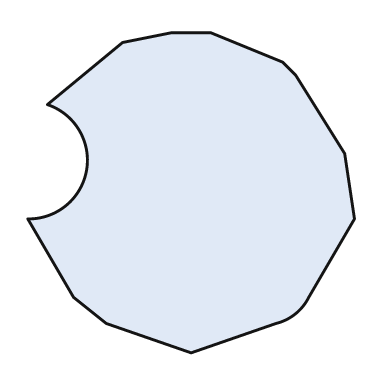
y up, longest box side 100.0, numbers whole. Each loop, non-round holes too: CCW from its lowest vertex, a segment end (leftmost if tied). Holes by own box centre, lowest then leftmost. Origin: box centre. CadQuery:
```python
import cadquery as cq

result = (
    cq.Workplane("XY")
    .moveTo(0.0, -49.0)
    .lineTo(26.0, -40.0)
    .threePointArc((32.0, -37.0), (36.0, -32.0))
    .lineTo(50.0, -8.0)
    .lineTo(47.0, 12.0)
    .lineTo(32.0, 36.0)
    .lineTo(28.0, 40.0)
    .lineTo(6.0, 49.0)
    .lineTo(-6.0, 49.0)
    .lineTo(-21.0, 46.0)
    .lineTo(-44.0, 27.0)
    .threePointArc((-32.0, 7.0), (-50.0, -8.0))
    .lineTo(-36.0, -32.0)
    .lineTo(-26.0, -40.0)
    .close()
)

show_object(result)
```